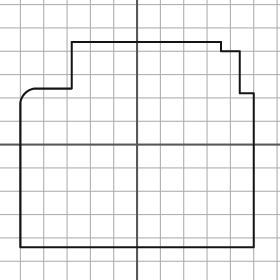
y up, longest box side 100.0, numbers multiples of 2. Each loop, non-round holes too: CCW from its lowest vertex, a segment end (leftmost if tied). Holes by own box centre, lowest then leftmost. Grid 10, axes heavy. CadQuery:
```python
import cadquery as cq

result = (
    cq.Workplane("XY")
    .moveTo(-50.0, -44.0)
    .lineTo(50.0, -44.0)
    .lineTo(50.0, 22.0)
    .lineTo(44.0, 22.0)
    .lineTo(44.0, 40.0)
    .lineTo(36.0, 40.0)
    .lineTo(36.0, 44.0)
    .lineTo(-28.0, 44.0)
    .lineTo(-28.0, 24.0)
    .lineTo(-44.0, 24.0)
    .threePointArc((-48.0, 22.0), (-50.0, 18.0))
    .close()
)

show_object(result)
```